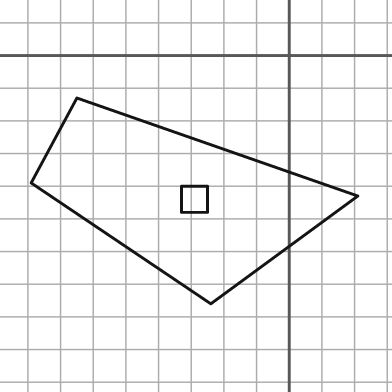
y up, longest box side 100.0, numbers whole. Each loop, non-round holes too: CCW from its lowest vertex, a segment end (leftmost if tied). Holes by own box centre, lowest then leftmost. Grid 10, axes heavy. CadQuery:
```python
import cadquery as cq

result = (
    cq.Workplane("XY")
    .moveTo(-24.0, -76.0)
    .lineTo(21.0, -43.0)
    .lineTo(-65.0, -13.0)
    .lineTo(-79.0, -39.0)
    .close()
    .moveTo(-33.0, -48.0)
    .lineTo(-25.0, -48.0)
    .lineTo(-25.0, -40.0)
    .lineTo(-33.0, -40.0)
    .close()
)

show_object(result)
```